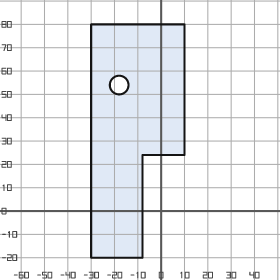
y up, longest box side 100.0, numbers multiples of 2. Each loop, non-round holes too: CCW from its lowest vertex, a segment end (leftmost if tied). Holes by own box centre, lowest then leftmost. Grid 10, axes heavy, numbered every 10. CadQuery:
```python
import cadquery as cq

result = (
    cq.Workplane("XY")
    .moveTo(-30.0, -20.0)
    .lineTo(-8.0, -20.0)
    .lineTo(-8.0, 24.0)
    .lineTo(10.0, 24.0)
    .lineTo(10.0, 80.0)
    .lineTo(-30.0, 80.0)
    .close()
    .moveTo(-18.0, 54.0)
    .circle(4.0)
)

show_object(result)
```